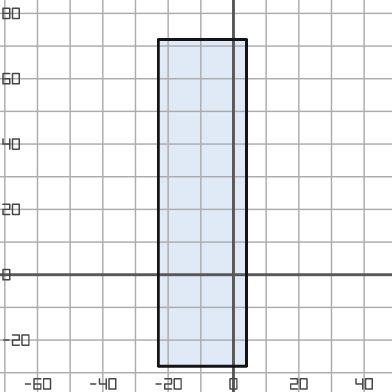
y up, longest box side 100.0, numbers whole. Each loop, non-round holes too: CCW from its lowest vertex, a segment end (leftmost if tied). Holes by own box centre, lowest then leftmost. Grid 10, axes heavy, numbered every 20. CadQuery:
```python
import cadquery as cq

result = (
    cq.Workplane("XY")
    .moveTo(-23.0, -28.0)
    .lineTo(4.0, -28.0)
    .lineTo(4.0, 72.0)
    .lineTo(-23.0, 72.0)
    .close()
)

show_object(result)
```